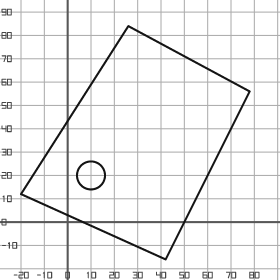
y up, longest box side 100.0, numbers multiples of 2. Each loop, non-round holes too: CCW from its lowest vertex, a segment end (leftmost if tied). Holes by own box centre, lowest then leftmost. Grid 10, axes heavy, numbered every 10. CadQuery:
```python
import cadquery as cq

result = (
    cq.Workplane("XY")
    .moveTo(42.0, -16.0)
    .lineTo(78.0, 56.0)
    .lineTo(26.0, 84.0)
    .lineTo(-20.0, 12.0)
    .close()
    .moveTo(10.0, 20.0)
    .circle(6.0)
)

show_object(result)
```